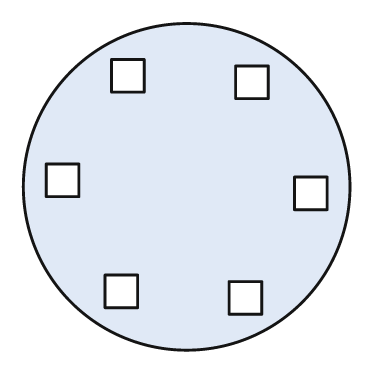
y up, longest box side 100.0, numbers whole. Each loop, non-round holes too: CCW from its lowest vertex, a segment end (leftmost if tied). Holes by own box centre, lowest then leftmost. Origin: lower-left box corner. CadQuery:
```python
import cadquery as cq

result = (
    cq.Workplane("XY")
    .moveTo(50.0, 50.0)
    .circle(50.0)
    .moveTo(63.0, 11.0)
    .lineTo(73.0, 11.0)
    .lineTo(73.0, 21.0)
    .lineTo(63.0, 21.0)
    .close()
    .moveTo(25.0, 13.0)
    .lineTo(35.0, 13.0)
    .lineTo(35.0, 23.0)
    .lineTo(25.0, 23.0)
    .close()
    .moveTo(83.0, 43.0)
    .lineTo(93.0, 43.0)
    .lineTo(93.0, 53.0)
    .lineTo(83.0, 53.0)
    .close()
    .moveTo(7.0, 47.0)
    .lineTo(17.0, 47.0)
    .lineTo(17.0, 57.0)
    .lineTo(7.0, 57.0)
    .close()
    .moveTo(65.0, 77.0)
    .lineTo(75.0, 77.0)
    .lineTo(75.0, 87.0)
    .lineTo(65.0, 87.0)
    .close()
    .moveTo(27.0, 79.0)
    .lineTo(37.0, 79.0)
    .lineTo(37.0, 89.0)
    .lineTo(27.0, 89.0)
    .close()
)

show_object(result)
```